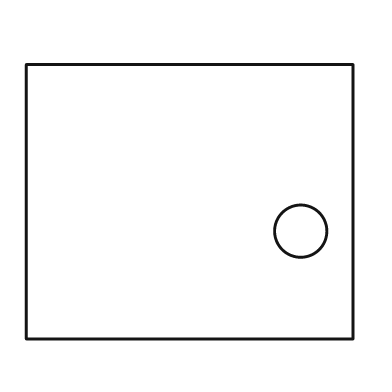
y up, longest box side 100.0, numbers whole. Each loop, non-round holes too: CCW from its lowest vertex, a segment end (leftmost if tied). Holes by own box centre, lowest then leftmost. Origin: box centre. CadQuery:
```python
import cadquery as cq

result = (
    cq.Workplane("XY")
    .moveTo(-50.0, -42.0)
    .lineTo(50.0, -42.0)
    .lineTo(50.0, 42.0)
    .lineTo(-50.0, 42.0)
    .close()
    .moveTo(34.0, -9.0)
    .circle(8.0)
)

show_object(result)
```